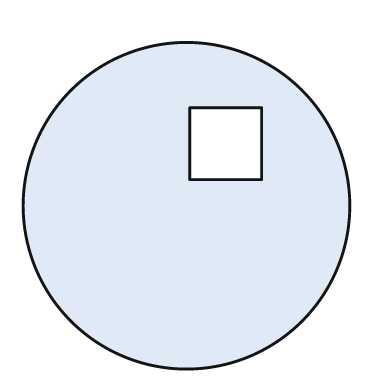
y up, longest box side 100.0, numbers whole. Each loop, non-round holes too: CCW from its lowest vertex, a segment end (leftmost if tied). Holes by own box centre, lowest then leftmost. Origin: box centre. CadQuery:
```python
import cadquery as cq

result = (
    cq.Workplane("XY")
    .moveTo(0.0, 0.0)
    .circle(50.0)
    .moveTo(1.0, 8.0)
    .lineTo(23.0, 8.0)
    .lineTo(23.0, 30.0)
    .lineTo(1.0, 30.0)
    .close()
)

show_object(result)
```